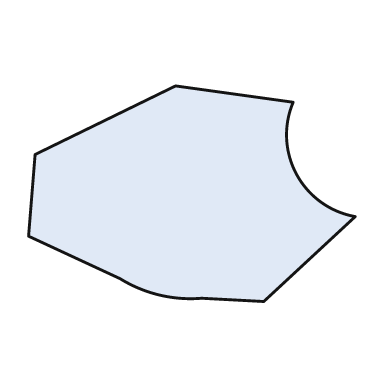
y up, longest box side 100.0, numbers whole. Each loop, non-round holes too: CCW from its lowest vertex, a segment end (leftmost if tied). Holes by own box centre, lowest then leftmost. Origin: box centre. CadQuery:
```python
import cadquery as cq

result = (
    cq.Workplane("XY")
    .moveTo(22.0, -33.0)
    .lineTo(50.0, -7.0)
    .threePointArc((32.0, 6.0), (31.0, 28.0))
    .lineTo(-5.0, 33.0)
    .lineTo(-48.0, 12.0)
    .lineTo(-50.0, -13.0)
    .lineTo(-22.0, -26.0)
    .threePointArc((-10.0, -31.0), (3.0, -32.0))
    .close()
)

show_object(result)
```